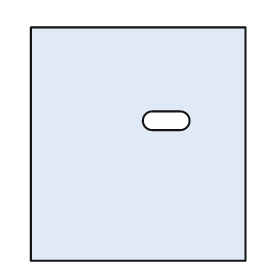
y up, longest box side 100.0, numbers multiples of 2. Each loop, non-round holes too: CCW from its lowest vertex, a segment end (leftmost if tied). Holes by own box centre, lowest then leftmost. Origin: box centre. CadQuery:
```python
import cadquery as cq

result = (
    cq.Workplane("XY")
    .moveTo(-46.0, -50.0)
    .lineTo(46.0, -50.0)
    .lineTo(46.0, 50.0)
    .lineTo(-46.0, 50.0)
    .close()
    .moveTo(6.0, 6.0)
    .lineTo(18.0, 6.0)
    .threePointArc((22.0, 10.0), (18.0, 14.0))
    .lineTo(6.0, 14.0)
    .threePointArc((2.0, 10.0), (6.0, 6.0))
    .close()
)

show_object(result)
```